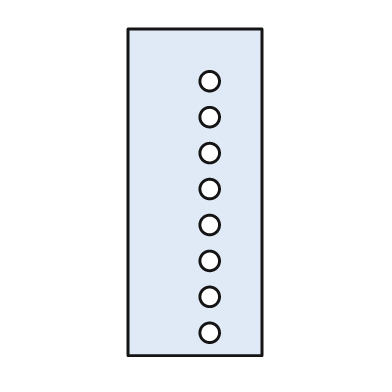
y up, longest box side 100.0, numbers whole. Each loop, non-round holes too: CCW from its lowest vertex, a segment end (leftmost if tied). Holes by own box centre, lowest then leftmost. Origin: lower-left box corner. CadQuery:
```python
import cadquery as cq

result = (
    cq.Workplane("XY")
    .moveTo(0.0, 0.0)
    .lineTo(41.0, 0.0)
    .lineTo(41.0, 100.0)
    .lineTo(0.0, 100.0)
    .close()
    .moveTo(25.0, 7.0)
    .circle(3.0)
    .moveTo(25.0, 18.0)
    .circle(3.0)
    .moveTo(25.0, 29.0)
    .circle(3.0)
    .moveTo(25.0, 40.0)
    .circle(3.0)
    .moveTo(25.0, 51.0)
    .circle(3.0)
    .moveTo(25.0, 62.0)
    .circle(3.0)
    .moveTo(25.0, 73.0)
    .circle(3.0)
    .moveTo(25.0, 84.0)
    .circle(3.0)
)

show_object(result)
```